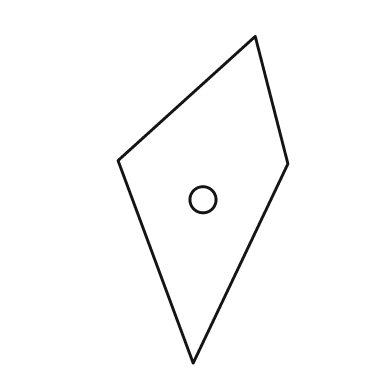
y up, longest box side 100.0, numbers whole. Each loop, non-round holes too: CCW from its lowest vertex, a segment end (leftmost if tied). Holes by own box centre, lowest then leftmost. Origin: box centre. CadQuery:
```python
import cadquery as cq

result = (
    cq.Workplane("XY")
    .moveTo(-3.0, -50.0)
    .lineTo(26.0, 11.0)
    .lineTo(16.0, 50.0)
    .lineTo(-26.0, 12.0)
    .close()
    .moveTo(0.0, 0.0)
    .circle(4.0)
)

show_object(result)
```